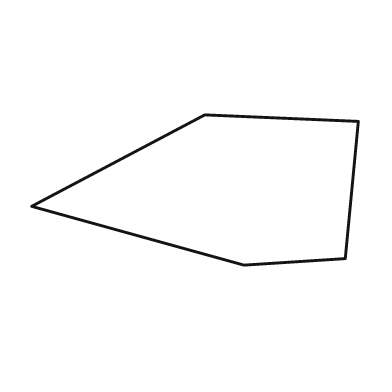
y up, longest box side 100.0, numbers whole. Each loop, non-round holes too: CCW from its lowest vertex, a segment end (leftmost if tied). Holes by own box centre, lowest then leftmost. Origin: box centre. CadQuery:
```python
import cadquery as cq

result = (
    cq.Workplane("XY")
    .moveTo(15.0, -23.0)
    .lineTo(46.0, -21.0)
    .lineTo(50.0, 21.0)
    .lineTo(3.0, 23.0)
    .lineTo(-50.0, -5.0)
    .close()
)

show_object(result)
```